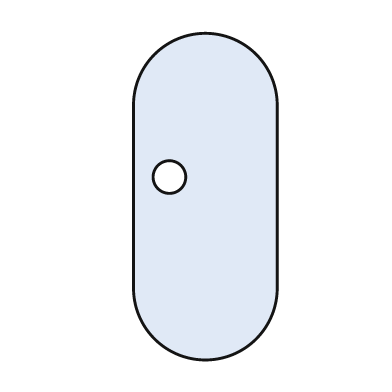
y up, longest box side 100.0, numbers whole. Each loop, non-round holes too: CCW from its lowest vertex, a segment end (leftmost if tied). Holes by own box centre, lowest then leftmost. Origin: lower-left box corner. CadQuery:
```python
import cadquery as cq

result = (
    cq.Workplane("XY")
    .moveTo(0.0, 22.0)
    .threePointArc((22.0, 0.0), (44.0, 22.0))
    .lineTo(44.0, 78.0)
    .threePointArc((22.0, 100.0), (0.0, 78.0))
    .close()
    .moveTo(11.0, 56.0)
    .circle(5.0)
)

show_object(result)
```